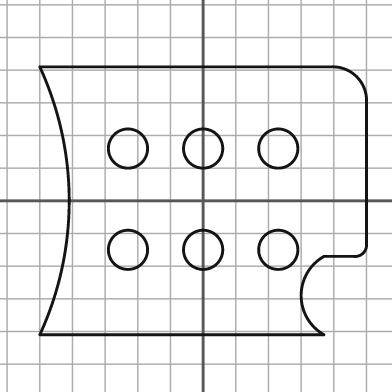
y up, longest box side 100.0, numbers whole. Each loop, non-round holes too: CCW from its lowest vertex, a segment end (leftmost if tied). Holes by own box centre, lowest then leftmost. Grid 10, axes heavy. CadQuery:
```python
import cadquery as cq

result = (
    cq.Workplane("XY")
    .moveTo(-50.0, -41.0)
    .lineTo(37.0, -41.0)
    .threePointArc((30.0, -29.0), (37.0, -17.0))
    .lineTo(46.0, -17.0)
    .threePointArc((49.0, -16.0), (50.0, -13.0))
    .lineTo(50.0, 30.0)
    .threePointArc((47.0, 38.0), (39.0, 41.0))
    .lineTo(-50.0, 41.0)
    .threePointArc((-41.0, 0.0), (-50.0, -41.0))
    .close()
    .moveTo(-23.0, -15.0)
    .circle(6.0)
    .moveTo(0.0, -15.0)
    .circle(6.0)
    .moveTo(23.0, -15.0)
    .circle(6.0)
    .moveTo(-23.0, 16.0)
    .circle(6.0)
    .moveTo(0.0, 16.0)
    .circle(6.0)
    .moveTo(23.0, 16.0)
    .circle(6.0)
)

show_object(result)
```